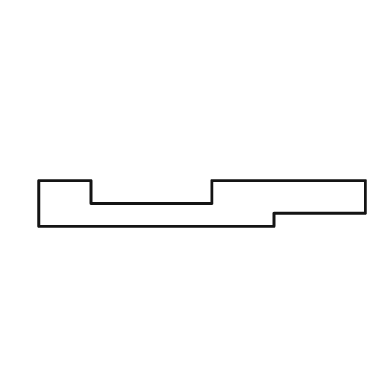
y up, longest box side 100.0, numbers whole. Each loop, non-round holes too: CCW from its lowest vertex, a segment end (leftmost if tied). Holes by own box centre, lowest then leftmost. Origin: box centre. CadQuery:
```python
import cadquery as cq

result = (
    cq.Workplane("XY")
    .moveTo(-50.0, -7.0)
    .lineTo(22.0, -7.0)
    .lineTo(22.0, -3.0)
    .lineTo(50.0, -3.0)
    .lineTo(50.0, 7.0)
    .lineTo(3.0, 7.0)
    .lineTo(3.0, 0.0)
    .lineTo(-34.0, 0.0)
    .lineTo(-34.0, 7.0)
    .lineTo(-50.0, 7.0)
    .close()
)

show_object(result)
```